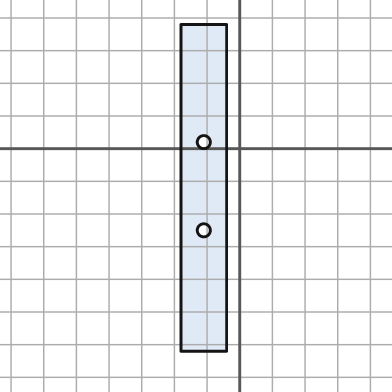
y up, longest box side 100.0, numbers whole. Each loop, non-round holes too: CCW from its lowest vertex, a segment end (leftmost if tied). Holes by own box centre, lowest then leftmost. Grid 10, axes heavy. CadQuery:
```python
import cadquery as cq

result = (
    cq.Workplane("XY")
    .moveTo(-18.0, -62.0)
    .lineTo(-4.0, -62.0)
    .lineTo(-4.0, 38.0)
    .lineTo(-18.0, 38.0)
    .close()
    .moveTo(-11.0, -25.0)
    .circle(2.0)
    .moveTo(-11.0, 2.0)
    .circle(2.0)
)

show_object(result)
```